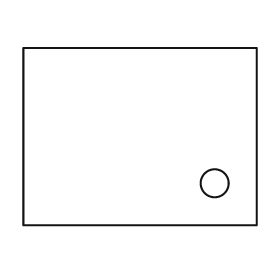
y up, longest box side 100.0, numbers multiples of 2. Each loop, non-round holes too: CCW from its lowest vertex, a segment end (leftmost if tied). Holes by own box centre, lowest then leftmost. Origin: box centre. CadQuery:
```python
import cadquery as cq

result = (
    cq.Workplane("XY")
    .moveTo(-50.0, -38.0)
    .lineTo(50.0, -38.0)
    .lineTo(50.0, 38.0)
    .lineTo(-50.0, 38.0)
    .close()
    .moveTo(32.0, -20.0)
    .circle(6.0)
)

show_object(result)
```